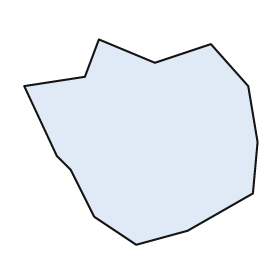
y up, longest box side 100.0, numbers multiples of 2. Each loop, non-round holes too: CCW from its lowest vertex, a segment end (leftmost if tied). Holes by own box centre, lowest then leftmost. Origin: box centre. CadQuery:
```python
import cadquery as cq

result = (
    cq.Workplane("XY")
    .moveTo(-2.0, -44.0)
    .lineTo(20.0, -38.0)
    .lineTo(48.0, -22.0)
    .lineTo(50.0, 0.0)
    .lineTo(46.0, 24.0)
    .lineTo(30.0, 42.0)
    .lineTo(6.0, 34.0)
    .lineTo(-18.0, 44.0)
    .lineTo(-24.0, 28.0)
    .lineTo(-50.0, 24.0)
    .lineTo(-36.0, -6.0)
    .lineTo(-30.0, -12.0)
    .lineTo(-20.0, -32.0)
    .close()
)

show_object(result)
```